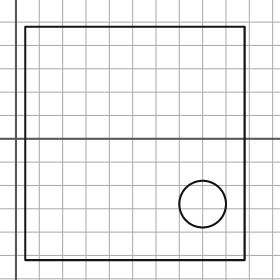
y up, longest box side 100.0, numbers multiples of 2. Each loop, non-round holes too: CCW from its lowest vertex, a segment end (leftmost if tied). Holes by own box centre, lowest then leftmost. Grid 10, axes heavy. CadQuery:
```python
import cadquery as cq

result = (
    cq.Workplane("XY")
    .moveTo(4.0, -52.0)
    .lineTo(98.0, -52.0)
    .lineTo(98.0, 48.0)
    .lineTo(4.0, 48.0)
    .close()
    .moveTo(80.0, -28.0)
    .circle(10.0)
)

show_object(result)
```